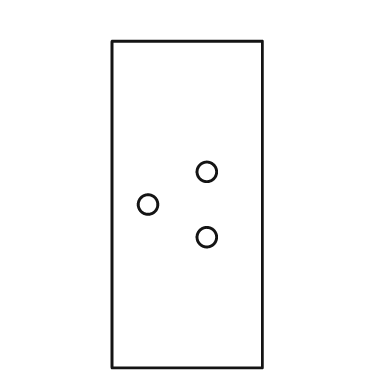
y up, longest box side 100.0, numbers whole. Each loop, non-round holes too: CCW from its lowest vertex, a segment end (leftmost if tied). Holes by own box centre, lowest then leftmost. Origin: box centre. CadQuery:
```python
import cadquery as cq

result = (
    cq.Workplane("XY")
    .moveTo(-23.0, -50.0)
    .lineTo(23.0, -50.0)
    .lineTo(23.0, 50.0)
    .lineTo(-23.0, 50.0)
    .close()
    .moveTo(6.0, -10.0)
    .circle(3.0)
    .moveTo(-12.0, 0.0)
    .circle(3.0)
    .moveTo(6.0, 10.0)
    .circle(3.0)
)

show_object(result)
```